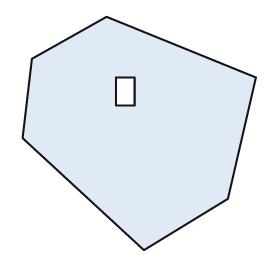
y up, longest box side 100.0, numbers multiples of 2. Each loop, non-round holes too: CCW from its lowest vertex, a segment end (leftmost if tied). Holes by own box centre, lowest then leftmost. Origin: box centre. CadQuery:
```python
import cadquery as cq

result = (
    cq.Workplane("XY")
    .moveTo(2.0, -50.0)
    .lineTo(38.0, -28.0)
    .lineTo(50.0, 24.0)
    .lineTo(-14.0, 50.0)
    .lineTo(-46.0, 32.0)
    .lineTo(-50.0, -2.0)
    .close()
    .moveTo(-10.0, 12.0)
    .lineTo(-2.0, 12.0)
    .lineTo(-2.0, 24.0)
    .lineTo(-10.0, 24.0)
    .close()
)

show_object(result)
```